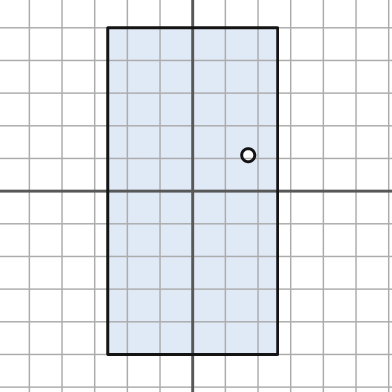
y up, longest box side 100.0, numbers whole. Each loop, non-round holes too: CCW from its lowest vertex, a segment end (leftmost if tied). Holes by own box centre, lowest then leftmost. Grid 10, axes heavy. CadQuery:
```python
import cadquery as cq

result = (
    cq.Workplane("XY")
    .moveTo(-26.0, -50.0)
    .lineTo(26.0, -50.0)
    .lineTo(26.0, 50.0)
    .lineTo(-26.0, 50.0)
    .close()
    .moveTo(17.0, 11.0)
    .circle(2.0)
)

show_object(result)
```